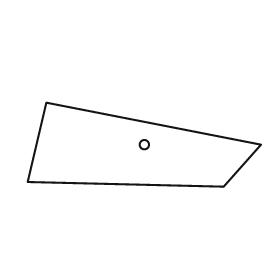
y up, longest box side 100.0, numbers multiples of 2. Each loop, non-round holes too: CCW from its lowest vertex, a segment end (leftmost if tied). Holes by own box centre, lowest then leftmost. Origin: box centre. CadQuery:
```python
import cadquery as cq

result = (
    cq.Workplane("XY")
    .moveTo(34.0, -18.0)
    .lineTo(50.0, 0.0)
    .lineTo(-42.0, 18.0)
    .lineTo(-50.0, -16.0)
    .close()
    .moveTo(0.0, 0.0)
    .circle(2.0)
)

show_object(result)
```